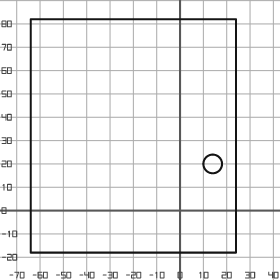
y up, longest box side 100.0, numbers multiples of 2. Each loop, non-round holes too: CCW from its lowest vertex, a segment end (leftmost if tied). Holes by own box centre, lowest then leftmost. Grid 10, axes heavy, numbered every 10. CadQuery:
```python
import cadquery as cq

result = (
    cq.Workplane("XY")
    .moveTo(-64.0, -18.0)
    .lineTo(24.0, -18.0)
    .lineTo(24.0, 82.0)
    .lineTo(-64.0, 82.0)
    .close()
    .moveTo(14.0, 20.0)
    .circle(4.0)
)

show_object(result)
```